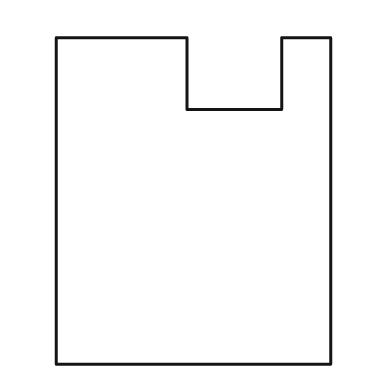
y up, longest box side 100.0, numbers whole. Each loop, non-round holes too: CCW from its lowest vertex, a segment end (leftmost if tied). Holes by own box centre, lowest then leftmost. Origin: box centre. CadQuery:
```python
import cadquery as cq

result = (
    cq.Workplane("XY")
    .moveTo(-42.0, -50.0)
    .lineTo(42.0, -50.0)
    .lineTo(42.0, 50.0)
    .lineTo(27.0, 50.0)
    .lineTo(27.0, 28.0)
    .lineTo(-2.0, 28.0)
    .lineTo(-2.0, 50.0)
    .lineTo(-42.0, 50.0)
    .close()
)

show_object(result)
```